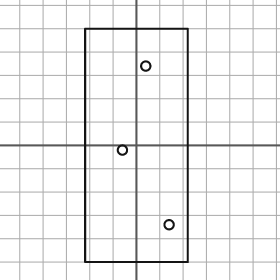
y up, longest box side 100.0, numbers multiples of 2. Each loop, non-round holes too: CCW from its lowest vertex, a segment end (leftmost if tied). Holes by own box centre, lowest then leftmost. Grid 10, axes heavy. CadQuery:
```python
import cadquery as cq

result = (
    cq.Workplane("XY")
    .moveTo(-22.0, -50.0)
    .lineTo(22.0, -50.0)
    .lineTo(22.0, 50.0)
    .lineTo(-22.0, 50.0)
    .close()
    .moveTo(14.0, -34.0)
    .circle(2.0)
    .moveTo(-6.0, -2.0)
    .circle(2.0)
    .moveTo(4.0, 34.0)
    .circle(2.0)
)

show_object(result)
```